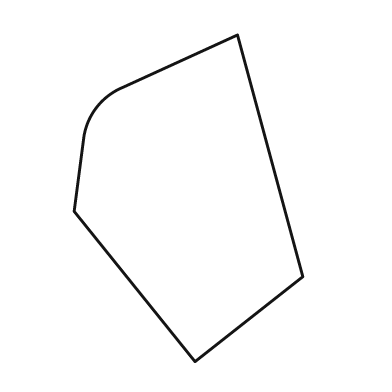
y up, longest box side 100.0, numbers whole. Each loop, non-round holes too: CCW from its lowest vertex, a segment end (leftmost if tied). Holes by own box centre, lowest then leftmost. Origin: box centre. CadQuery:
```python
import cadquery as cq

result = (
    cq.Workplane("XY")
    .moveTo(2.0, -50.0)
    .lineTo(35.0, -24.0)
    .lineTo(15.0, 50.0)
    .lineTo(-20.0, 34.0)
    .threePointArc((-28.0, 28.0), (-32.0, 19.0))
    .lineTo(-35.0, -4.0)
    .close()
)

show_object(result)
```